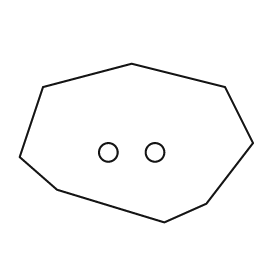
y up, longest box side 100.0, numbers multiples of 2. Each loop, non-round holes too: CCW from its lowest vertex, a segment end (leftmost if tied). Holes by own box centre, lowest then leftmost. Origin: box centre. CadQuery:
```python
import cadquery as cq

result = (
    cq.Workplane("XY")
    .moveTo(12.0, -34.0)
    .lineTo(30.0, -26.0)
    .lineTo(50.0, 0.0)
    .lineTo(38.0, 24.0)
    .lineTo(-2.0, 34.0)
    .lineTo(-40.0, 24.0)
    .lineTo(-50.0, -6.0)
    .lineTo(-34.0, -20.0)
    .close()
    .moveTo(-12.0, -4.0)
    .circle(4.0)
    .moveTo(8.0, -4.0)
    .circle(4.0)
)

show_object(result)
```